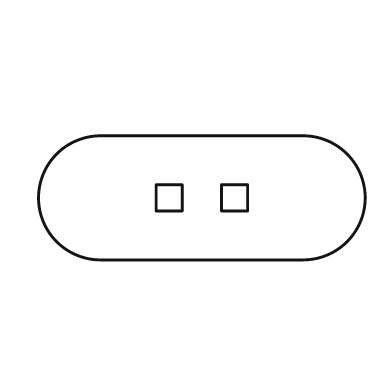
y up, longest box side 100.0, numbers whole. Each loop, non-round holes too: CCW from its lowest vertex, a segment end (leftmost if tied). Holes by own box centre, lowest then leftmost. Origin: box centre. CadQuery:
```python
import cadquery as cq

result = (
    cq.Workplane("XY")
    .moveTo(-31.0, -19.0)
    .lineTo(31.0, -19.0)
    .threePointArc((50.0, 0.0), (31.0, 19.0))
    .lineTo(-31.0, 19.0)
    .threePointArc((-50.0, 0.0), (-31.0, -19.0))
    .close()
    .moveTo(-14.0, -4.0)
    .lineTo(-6.0, -4.0)
    .lineTo(-6.0, 4.0)
    .lineTo(-14.0, 4.0)
    .close()
    .moveTo(6.0, -4.0)
    .lineTo(14.0, -4.0)
    .lineTo(14.0, 4.0)
    .lineTo(6.0, 4.0)
    .close()
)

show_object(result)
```